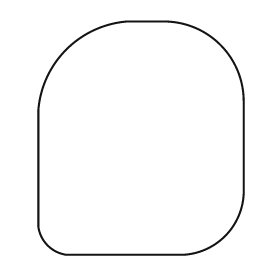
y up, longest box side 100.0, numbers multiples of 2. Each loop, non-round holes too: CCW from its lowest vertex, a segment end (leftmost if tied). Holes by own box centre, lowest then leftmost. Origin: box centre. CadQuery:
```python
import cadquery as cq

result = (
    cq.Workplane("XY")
    .moveTo(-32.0, -50.0)
    .lineTo(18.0, -50.0)
    .threePointArc((36.0, -42.0), (44.0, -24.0))
    .lineTo(44.0, 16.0)
    .threePointArc((34.0, 40.0), (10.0, 50.0))
    .lineTo(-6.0, 50.0)
    .threePointArc((-32.0, 38.0), (-44.0, 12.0))
    .lineTo(-44.0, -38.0)
    .threePointArc((-40.0, -46.0), (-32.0, -50.0))
    .close()
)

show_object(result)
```